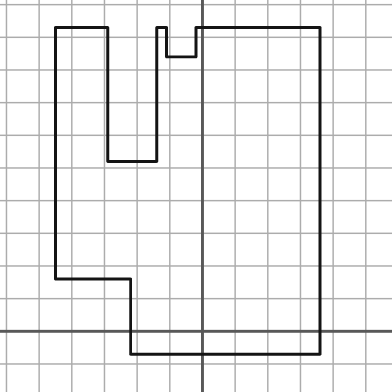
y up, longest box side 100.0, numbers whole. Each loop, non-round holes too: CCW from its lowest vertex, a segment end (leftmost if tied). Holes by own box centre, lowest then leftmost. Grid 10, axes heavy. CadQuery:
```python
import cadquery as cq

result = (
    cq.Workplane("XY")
    .moveTo(-22.0, -7.0)
    .lineTo(36.0, -7.0)
    .lineTo(36.0, 93.0)
    .lineTo(-2.0, 93.0)
    .lineTo(-2.0, 84.0)
    .lineTo(-11.0, 84.0)
    .lineTo(-11.0, 93.0)
    .lineTo(-14.0, 93.0)
    .lineTo(-14.0, 52.0)
    .lineTo(-29.0, 52.0)
    .lineTo(-29.0, 93.0)
    .lineTo(-45.0, 93.0)
    .lineTo(-45.0, 16.0)
    .lineTo(-22.0, 16.0)
    .close()
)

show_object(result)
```